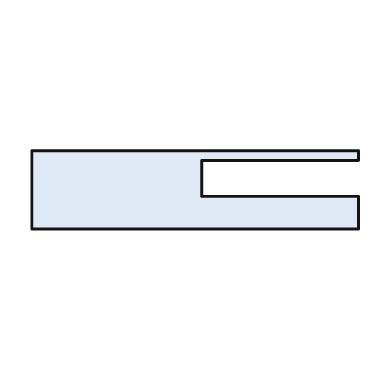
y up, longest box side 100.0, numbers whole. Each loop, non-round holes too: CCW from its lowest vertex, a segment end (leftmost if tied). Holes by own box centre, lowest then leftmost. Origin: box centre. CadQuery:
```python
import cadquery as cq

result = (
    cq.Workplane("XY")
    .moveTo(-50.0, -12.0)
    .lineTo(50.0, -12.0)
    .lineTo(50.0, -2.0)
    .lineTo(2.0, -2.0)
    .lineTo(2.0, 9.0)
    .lineTo(50.0, 9.0)
    .lineTo(50.0, 12.0)
    .lineTo(-50.0, 12.0)
    .close()
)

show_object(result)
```